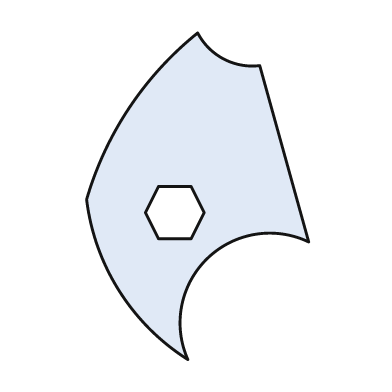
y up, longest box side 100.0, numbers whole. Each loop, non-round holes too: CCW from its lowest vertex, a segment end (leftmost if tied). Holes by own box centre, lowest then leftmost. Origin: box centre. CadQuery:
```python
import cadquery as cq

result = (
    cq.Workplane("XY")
    .moveTo(-3.0, -50.0)
    .threePointArc((3.0, -19.0), (34.0, -14.0))
    .lineTo(19.0, 40.0)
    .threePointArc((8.0, 42.0), (0.0, 50.0))
    .threePointArc((-21.0, 27.0), (-34.0, -1.0))
    .threePointArc((-24.0, -29.0), (-3.0, -50.0))
    .close()
    .moveTo(-12.0, -13.0)
    .lineTo(-2.0, -13.0)
    .lineTo(2.0, -5.0)
    .lineTo(-2.0, 3.0)
    .lineTo(-12.0, 3.0)
    .lineTo(-16.0, -5.0)
    .close()
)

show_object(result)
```